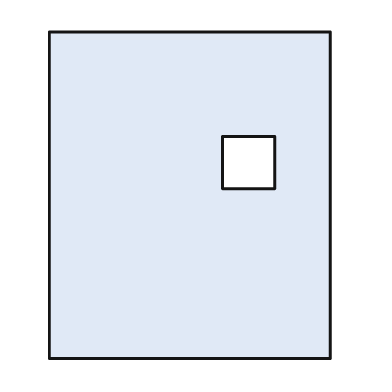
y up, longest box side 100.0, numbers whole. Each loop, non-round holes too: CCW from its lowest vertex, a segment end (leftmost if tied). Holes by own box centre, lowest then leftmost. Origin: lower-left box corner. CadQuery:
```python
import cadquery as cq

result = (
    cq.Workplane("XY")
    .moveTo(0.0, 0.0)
    .lineTo(86.0, 0.0)
    .lineTo(86.0, 100.0)
    .lineTo(0.0, 100.0)
    .close()
    .moveTo(53.0, 52.0)
    .lineTo(69.0, 52.0)
    .lineTo(69.0, 68.0)
    .lineTo(53.0, 68.0)
    .close()
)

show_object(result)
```